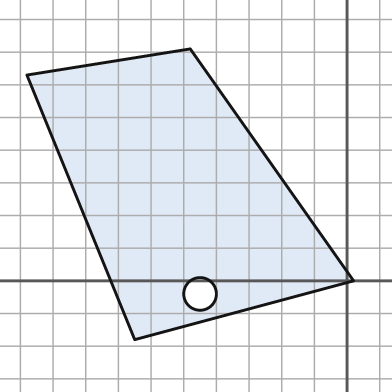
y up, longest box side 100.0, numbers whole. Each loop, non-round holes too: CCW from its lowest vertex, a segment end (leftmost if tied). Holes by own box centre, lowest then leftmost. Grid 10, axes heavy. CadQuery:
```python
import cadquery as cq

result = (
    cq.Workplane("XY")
    .moveTo(-65.0, -18.0)
    .lineTo(2.0, 0.0)
    .lineTo(-48.0, 71.0)
    .lineTo(-98.0, 63.0)
    .close()
    .moveTo(-45.0, -4.0)
    .circle(5.0)
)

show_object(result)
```